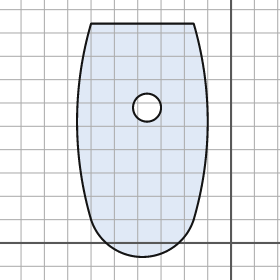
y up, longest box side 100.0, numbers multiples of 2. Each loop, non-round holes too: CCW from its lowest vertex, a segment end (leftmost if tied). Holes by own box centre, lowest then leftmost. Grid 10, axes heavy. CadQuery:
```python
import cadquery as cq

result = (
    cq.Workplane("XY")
    .moveTo(-60.0, 10.0)
    .threePointArc((-38.0, -6.0), (-16.0, 10.0))
    .threePointArc((-10.0, 52.0), (-16.0, 94.0))
    .lineTo(-60.0, 94.0)
    .threePointArc((-66.0, 52.0), (-60.0, 10.0))
    .close()
    .moveTo(-36.0, 58.0)
    .circle(6.0)
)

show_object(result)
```